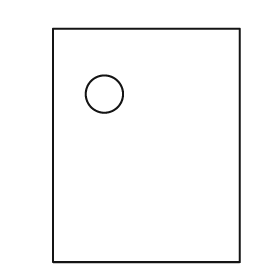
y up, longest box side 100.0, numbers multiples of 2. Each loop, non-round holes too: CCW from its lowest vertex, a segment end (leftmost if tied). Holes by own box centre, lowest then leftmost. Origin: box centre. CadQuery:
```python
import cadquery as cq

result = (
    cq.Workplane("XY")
    .moveTo(-40.0, -50.0)
    .lineTo(40.0, -50.0)
    .lineTo(40.0, 50.0)
    .lineTo(-40.0, 50.0)
    .close()
    .moveTo(-18.0, 22.0)
    .circle(8.0)
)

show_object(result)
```